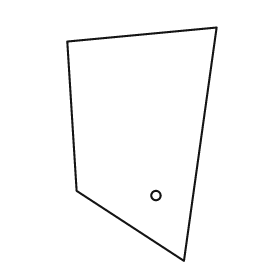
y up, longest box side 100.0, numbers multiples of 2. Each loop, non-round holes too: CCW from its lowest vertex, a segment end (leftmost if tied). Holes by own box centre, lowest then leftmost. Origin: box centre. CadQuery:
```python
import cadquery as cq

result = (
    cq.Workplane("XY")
    .moveTo(18.0, -50.0)
    .lineTo(32.0, 50.0)
    .lineTo(-32.0, 44.0)
    .lineTo(-28.0, -20.0)
    .close()
    .moveTo(6.0, -22.0)
    .circle(2.0)
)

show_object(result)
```